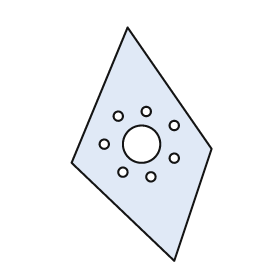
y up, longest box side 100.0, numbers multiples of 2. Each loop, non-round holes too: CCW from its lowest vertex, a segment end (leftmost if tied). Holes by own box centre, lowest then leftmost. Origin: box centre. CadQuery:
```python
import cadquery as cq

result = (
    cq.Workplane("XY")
    .moveTo(14.0, -50.0)
    .lineTo(30.0, -2.0)
    .lineTo(-6.0, 50.0)
    .lineTo(-30.0, -8.0)
    .close()
    .moveTo(4.0, -14.0)
    .circle(2.0)
    .moveTo(-8.0, -12.0)
    .circle(2.0)
    .moveTo(14.0, -6.0)
    .circle(2.0)
    .moveTo(-16.0, 0.0)
    .circle(2.0)
    .moveTo(0.0, 0.0)
    .circle(8.0)
    .moveTo(14.0, 8.0)
    .circle(2.0)
    .moveTo(-10.0, 12.0)
    .circle(2.0)
    .moveTo(2.0, 14.0)
    .circle(2.0)
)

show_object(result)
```